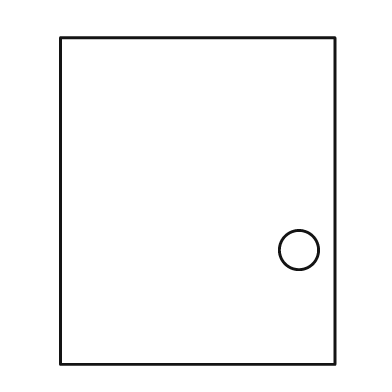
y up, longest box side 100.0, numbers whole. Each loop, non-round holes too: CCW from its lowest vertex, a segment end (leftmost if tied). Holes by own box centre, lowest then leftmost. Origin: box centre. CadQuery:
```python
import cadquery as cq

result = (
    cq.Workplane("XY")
    .moveTo(-42.0, -50.0)
    .lineTo(42.0, -50.0)
    .lineTo(42.0, 50.0)
    .lineTo(-42.0, 50.0)
    .close()
    .moveTo(31.0, -15.0)
    .circle(6.0)
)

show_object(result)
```